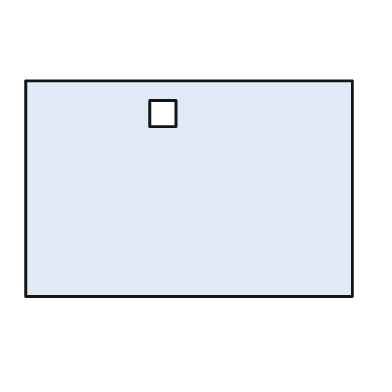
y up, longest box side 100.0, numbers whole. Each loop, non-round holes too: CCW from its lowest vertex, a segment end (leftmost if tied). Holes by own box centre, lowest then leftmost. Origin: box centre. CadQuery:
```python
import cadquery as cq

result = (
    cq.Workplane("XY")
    .moveTo(-50.0, -33.0)
    .lineTo(50.0, -33.0)
    .lineTo(50.0, 33.0)
    .lineTo(-50.0, 33.0)
    .close()
    .moveTo(-12.0, 19.0)
    .lineTo(-4.0, 19.0)
    .lineTo(-4.0, 27.0)
    .lineTo(-12.0, 27.0)
    .close()
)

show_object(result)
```